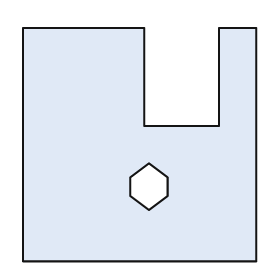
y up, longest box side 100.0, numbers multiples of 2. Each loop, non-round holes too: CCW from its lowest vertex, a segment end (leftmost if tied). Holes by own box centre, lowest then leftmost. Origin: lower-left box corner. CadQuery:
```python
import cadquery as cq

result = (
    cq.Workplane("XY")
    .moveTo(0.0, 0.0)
    .lineTo(100.0, 0.0)
    .lineTo(100.0, 100.0)
    .lineTo(84.0, 100.0)
    .lineTo(84.0, 58.0)
    .lineTo(52.0, 58.0)
    .lineTo(52.0, 100.0)
    .lineTo(0.0, 100.0)
    .close()
    .moveTo(54.0, 22.0)
    .lineTo(62.0, 28.0)
    .lineTo(62.0, 36.0)
    .lineTo(54.0, 42.0)
    .lineTo(46.0, 36.0)
    .lineTo(46.0, 28.0)
    .close()
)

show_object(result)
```